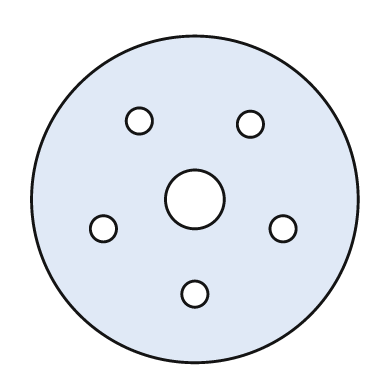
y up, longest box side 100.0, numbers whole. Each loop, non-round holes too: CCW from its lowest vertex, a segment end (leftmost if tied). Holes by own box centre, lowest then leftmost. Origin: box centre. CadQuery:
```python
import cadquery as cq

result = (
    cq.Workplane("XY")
    .moveTo(0.0, 0.0)
    .circle(50.0)
    .moveTo(0.0, -29.0)
    .circle(4.0)
    .moveTo(-28.0, -9.0)
    .circle(4.0)
    .moveTo(27.0, -9.0)
    .circle(4.0)
    .moveTo(0.0, 0.0)
    .circle(9.0)
    .moveTo(17.0, 23.0)
    .circle(4.0)
    .moveTo(-17.0, 24.0)
    .circle(4.0)
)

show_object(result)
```